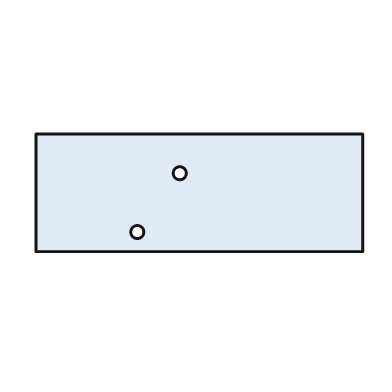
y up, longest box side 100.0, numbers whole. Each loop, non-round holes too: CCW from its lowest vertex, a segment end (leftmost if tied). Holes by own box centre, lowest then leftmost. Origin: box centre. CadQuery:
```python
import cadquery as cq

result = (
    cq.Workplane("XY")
    .moveTo(-50.0, -18.0)
    .lineTo(50.0, -18.0)
    .lineTo(50.0, 18.0)
    .lineTo(-50.0, 18.0)
    .close()
    .moveTo(-19.0, -12.0)
    .circle(2.0)
    .moveTo(-6.0, 6.0)
    .circle(2.0)
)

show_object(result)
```